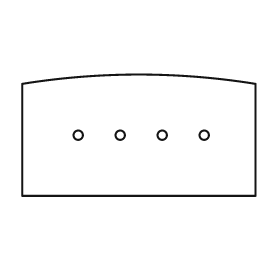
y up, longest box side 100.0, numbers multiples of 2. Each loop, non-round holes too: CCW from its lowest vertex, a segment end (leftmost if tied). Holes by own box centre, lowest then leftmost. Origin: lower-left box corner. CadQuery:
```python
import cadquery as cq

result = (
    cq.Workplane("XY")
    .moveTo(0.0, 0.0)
    .lineTo(100.0, 0.0)
    .lineTo(100.0, 48.0)
    .threePointArc((50.0, 52.0), (0.0, 48.0))
    .close()
    .moveTo(24.0, 26.0)
    .circle(2.0)
    .moveTo(42.0, 26.0)
    .circle(2.0)
    .moveTo(60.0, 26.0)
    .circle(2.0)
    .moveTo(78.0, 26.0)
    .circle(2.0)
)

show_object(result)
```